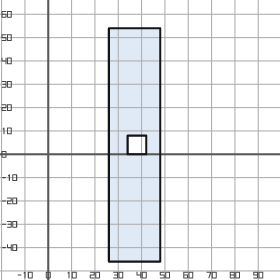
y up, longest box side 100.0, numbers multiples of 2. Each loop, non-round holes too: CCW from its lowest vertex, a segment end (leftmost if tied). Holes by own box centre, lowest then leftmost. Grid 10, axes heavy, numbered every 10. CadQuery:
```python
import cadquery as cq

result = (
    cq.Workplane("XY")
    .moveTo(26.0, -46.0)
    .lineTo(48.0, -46.0)
    .lineTo(48.0, 54.0)
    .lineTo(26.0, 54.0)
    .close()
    .moveTo(34.0, 0.0)
    .lineTo(42.0, 0.0)
    .lineTo(42.0, 8.0)
    .lineTo(34.0, 8.0)
    .close()
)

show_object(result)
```